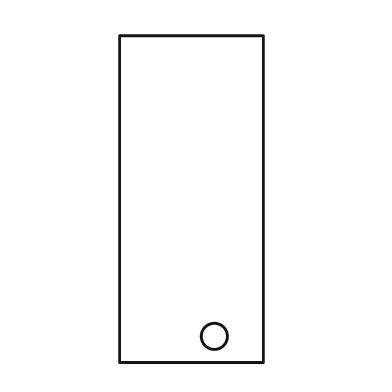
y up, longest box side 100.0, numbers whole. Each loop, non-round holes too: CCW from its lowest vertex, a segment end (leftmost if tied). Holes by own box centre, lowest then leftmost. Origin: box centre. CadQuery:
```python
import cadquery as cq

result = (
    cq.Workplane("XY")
    .moveTo(-22.0, -50.0)
    .lineTo(22.0, -50.0)
    .lineTo(22.0, 50.0)
    .lineTo(-22.0, 50.0)
    .close()
    .moveTo(7.0, -42.0)
    .circle(4.0)
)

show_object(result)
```